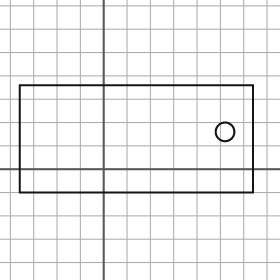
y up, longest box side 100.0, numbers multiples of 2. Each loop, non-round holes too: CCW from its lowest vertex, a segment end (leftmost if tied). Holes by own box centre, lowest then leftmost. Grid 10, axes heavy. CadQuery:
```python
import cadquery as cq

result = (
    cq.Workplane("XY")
    .moveTo(-36.0, -10.0)
    .lineTo(64.0, -10.0)
    .lineTo(64.0, 36.0)
    .lineTo(-36.0, 36.0)
    .close()
    .moveTo(52.0, 16.0)
    .circle(4.0)
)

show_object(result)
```